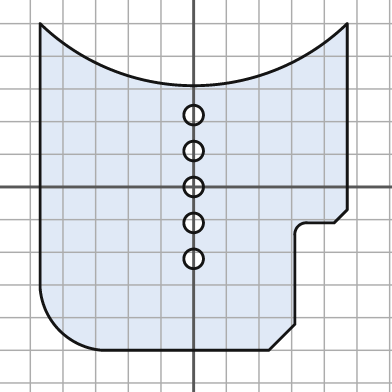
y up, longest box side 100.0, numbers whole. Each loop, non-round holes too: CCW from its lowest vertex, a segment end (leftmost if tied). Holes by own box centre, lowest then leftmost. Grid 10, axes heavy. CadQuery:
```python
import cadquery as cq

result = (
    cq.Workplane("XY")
    .moveTo(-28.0, -50.0)
    .lineTo(23.0, -50.0)
    .lineTo(31.0, -42.0)
    .lineTo(31.0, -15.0)
    .threePointArc((32.0, -12.0), (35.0, -11.0))
    .lineTo(43.0, -11.0)
    .lineTo(47.0, -7.0)
    .lineTo(47.0, 50.0)
    .threePointArc((0.0, 31.0), (-47.0, 50.0))
    .lineTo(-47.0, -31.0)
    .threePointArc((-41.0, -44.0), (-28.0, -50.0))
    .close()
    .moveTo(0.0, -22.0)
    .circle(3.0)
    .moveTo(0.0, -11.0)
    .circle(3.0)
    .moveTo(0.0, 0.0)
    .circle(3.0)
    .moveTo(0.0, 11.0)
    .circle(3.0)
    .moveTo(0.0, 22.0)
    .circle(3.0)
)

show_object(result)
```